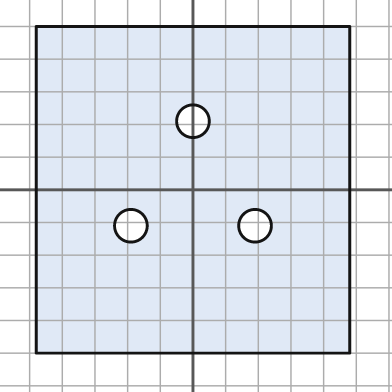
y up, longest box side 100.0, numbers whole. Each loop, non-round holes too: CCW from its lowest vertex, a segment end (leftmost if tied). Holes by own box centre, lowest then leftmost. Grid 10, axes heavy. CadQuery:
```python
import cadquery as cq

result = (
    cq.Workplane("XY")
    .moveTo(-48.0, -50.0)
    .lineTo(48.0, -50.0)
    .lineTo(48.0, 50.0)
    .lineTo(-48.0, 50.0)
    .close()
    .moveTo(-19.0, -11.0)
    .circle(5.0)
    .moveTo(19.0, -11.0)
    .circle(5.0)
    .moveTo(0.0, 21.0)
    .circle(5.0)
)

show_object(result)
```